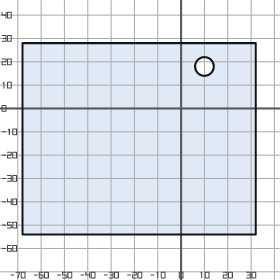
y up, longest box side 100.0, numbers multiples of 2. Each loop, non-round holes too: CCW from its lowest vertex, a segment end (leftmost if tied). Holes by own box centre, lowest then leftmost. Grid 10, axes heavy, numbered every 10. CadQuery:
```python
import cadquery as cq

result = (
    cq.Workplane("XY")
    .moveTo(-68.0, -54.0)
    .lineTo(32.0, -54.0)
    .lineTo(32.0, 28.0)
    .lineTo(-68.0, 28.0)
    .close()
    .moveTo(10.0, 18.0)
    .circle(4.0)
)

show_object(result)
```